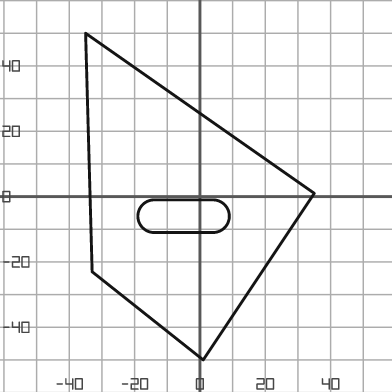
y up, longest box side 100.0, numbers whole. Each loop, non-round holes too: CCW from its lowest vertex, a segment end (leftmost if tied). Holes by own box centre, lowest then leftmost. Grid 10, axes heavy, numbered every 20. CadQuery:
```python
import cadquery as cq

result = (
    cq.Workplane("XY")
    .moveTo(1.0, -50.0)
    .lineTo(35.0, 1.0)
    .lineTo(-35.0, 50.0)
    .lineTo(-33.0, -23.0)
    .close()
    .moveTo(-14.0, -11.0)
    .lineTo(4.0, -11.0)
    .threePointArc((9.0, -6.0), (4.0, -1.0))
    .lineTo(-14.0, -1.0)
    .threePointArc((-19.0, -6.0), (-14.0, -11.0))
    .close()
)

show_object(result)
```